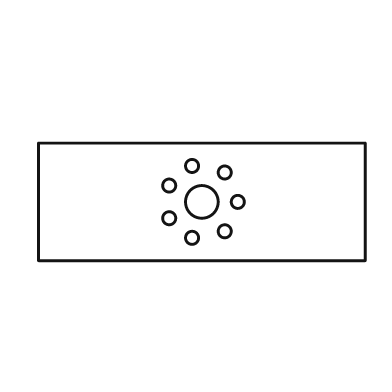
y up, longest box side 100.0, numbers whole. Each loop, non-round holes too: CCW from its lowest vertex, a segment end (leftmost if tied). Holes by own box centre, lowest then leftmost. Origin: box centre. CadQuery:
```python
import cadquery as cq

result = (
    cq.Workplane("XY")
    .moveTo(-50.0, -18.0)
    .lineTo(50.0, -18.0)
    .lineTo(50.0, 18.0)
    .lineTo(-50.0, 18.0)
    .close()
    .moveTo(-3.0, -11.0)
    .circle(2.0)
    .moveTo(7.0, -9.0)
    .circle(2.0)
    .moveTo(-10.0, -5.0)
    .circle(2.0)
    .moveTo(0.0, 0.0)
    .circle(5.0)
    .moveTo(11.0, 0.0)
    .circle(2.0)
    .moveTo(-10.0, 5.0)
    .circle(2.0)
    .moveTo(7.0, 9.0)
    .circle(2.0)
    .moveTo(-3.0, 11.0)
    .circle(2.0)
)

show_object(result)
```